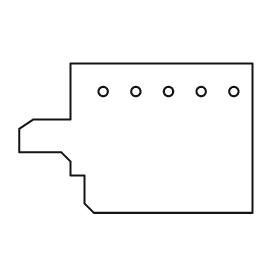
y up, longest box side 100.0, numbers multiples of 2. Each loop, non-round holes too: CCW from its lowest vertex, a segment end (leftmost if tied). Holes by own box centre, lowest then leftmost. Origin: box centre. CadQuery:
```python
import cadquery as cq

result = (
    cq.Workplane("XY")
    .moveTo(-18.0, -32.0)
    .lineTo(50.0, -32.0)
    .lineTo(50.0, 32.0)
    .lineTo(-28.0, 32.0)
    .lineTo(-28.0, 8.0)
    .lineTo(-44.0, 8.0)
    .lineTo(-50.0, 4.0)
    .lineTo(-50.0, -6.0)
    .lineTo(-32.0, -6.0)
    .lineTo(-28.0, -10.0)
    .lineTo(-28.0, -16.0)
    .lineTo(-22.0, -16.0)
    .lineTo(-22.0, -28.0)
    .close()
    .moveTo(-14.0, 20.0)
    .circle(2.0)
    .moveTo(0.0, 20.0)
    .circle(2.0)
    .moveTo(14.0, 20.0)
    .circle(2.0)
    .moveTo(28.0, 20.0)
    .circle(2.0)
    .moveTo(42.0, 20.0)
    .circle(2.0)
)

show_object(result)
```